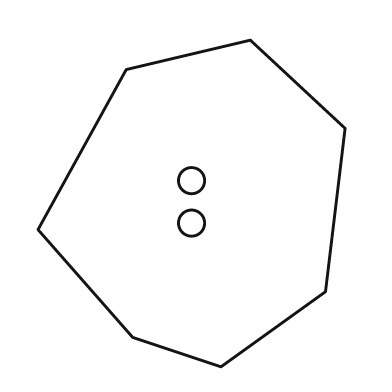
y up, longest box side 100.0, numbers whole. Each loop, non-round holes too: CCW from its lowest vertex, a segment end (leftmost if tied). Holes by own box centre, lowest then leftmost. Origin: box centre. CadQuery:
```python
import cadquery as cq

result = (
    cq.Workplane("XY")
    .moveTo(9.0, -50.0)
    .lineTo(41.0, -27.0)
    .lineTo(47.0, 23.0)
    .lineTo(18.0, 50.0)
    .lineTo(-20.0, 41.0)
    .lineTo(-47.0, -8.0)
    .lineTo(-18.0, -41.0)
    .close()
    .moveTo(0.0, -6.0)
    .circle(4.0)
    .moveTo(0.0, 7.0)
    .circle(4.0)
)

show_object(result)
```